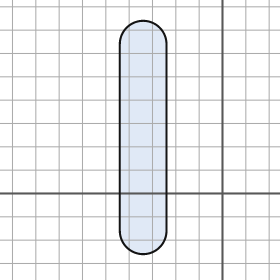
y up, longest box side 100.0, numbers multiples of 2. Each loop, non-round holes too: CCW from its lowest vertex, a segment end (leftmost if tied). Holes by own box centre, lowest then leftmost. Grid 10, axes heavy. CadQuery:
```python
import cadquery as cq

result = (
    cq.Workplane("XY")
    .moveTo(-44.0, -16.0)
    .threePointArc((-34.0, -26.0), (-24.0, -16.0))
    .lineTo(-24.0, 64.0)
    .threePointArc((-34.0, 74.0), (-44.0, 64.0))
    .close()
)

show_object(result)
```